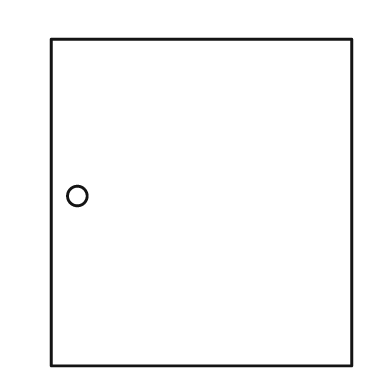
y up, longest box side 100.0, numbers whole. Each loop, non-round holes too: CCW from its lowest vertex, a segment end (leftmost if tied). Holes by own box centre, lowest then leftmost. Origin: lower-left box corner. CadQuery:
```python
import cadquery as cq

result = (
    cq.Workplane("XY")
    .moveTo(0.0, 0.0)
    .lineTo(92.0, 0.0)
    .lineTo(92.0, 100.0)
    .lineTo(0.0, 100.0)
    .close()
    .moveTo(8.0, 52.0)
    .circle(3.0)
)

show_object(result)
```